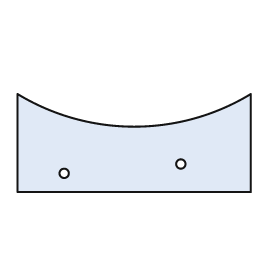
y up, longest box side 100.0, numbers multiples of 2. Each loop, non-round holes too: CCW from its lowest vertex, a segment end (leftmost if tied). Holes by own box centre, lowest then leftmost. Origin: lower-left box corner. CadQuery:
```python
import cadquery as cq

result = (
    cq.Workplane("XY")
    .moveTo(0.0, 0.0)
    .lineTo(100.0, 0.0)
    .lineTo(100.0, 42.0)
    .threePointArc((50.0, 28.0), (0.0, 42.0))
    .close()
    .moveTo(20.0, 8.0)
    .circle(2.0)
    .moveTo(70.0, 12.0)
    .circle(2.0)
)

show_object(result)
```